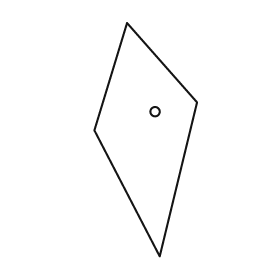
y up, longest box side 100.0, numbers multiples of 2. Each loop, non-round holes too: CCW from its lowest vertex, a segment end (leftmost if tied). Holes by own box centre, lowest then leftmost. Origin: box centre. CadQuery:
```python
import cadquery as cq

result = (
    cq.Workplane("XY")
    .moveTo(6.0, -50.0)
    .lineTo(22.0, 16.0)
    .lineTo(-8.0, 50.0)
    .lineTo(-22.0, 4.0)
    .close()
    .moveTo(4.0, 12.0)
    .circle(2.0)
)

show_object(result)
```